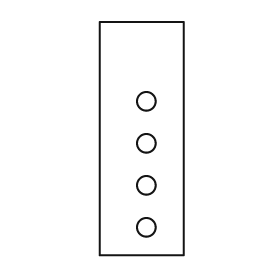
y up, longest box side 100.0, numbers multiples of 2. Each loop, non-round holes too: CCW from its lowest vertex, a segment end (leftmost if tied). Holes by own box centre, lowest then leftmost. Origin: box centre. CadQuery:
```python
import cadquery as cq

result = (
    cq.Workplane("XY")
    .moveTo(-18.0, -50.0)
    .lineTo(18.0, -50.0)
    .lineTo(18.0, 50.0)
    .lineTo(-18.0, 50.0)
    .close()
    .moveTo(2.0, -38.0)
    .circle(4.0)
    .moveTo(2.0, -20.0)
    .circle(4.0)
    .moveTo(2.0, -2.0)
    .circle(4.0)
    .moveTo(2.0, 16.0)
    .circle(4.0)
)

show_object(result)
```